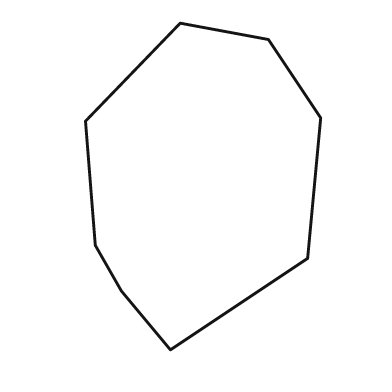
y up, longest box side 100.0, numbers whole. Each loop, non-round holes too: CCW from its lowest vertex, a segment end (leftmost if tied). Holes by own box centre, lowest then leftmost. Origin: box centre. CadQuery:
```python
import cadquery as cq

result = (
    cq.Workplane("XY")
    .moveTo(-10.0, -50.0)
    .lineTo(32.0, -22.0)
    .lineTo(36.0, 21.0)
    .lineTo(20.0, 45.0)
    .lineTo(-7.0, 50.0)
    .lineTo(-36.0, 20.0)
    .lineTo(-33.0, -18.0)
    .lineTo(-25.0, -32.0)
    .close()
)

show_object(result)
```